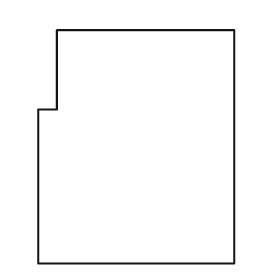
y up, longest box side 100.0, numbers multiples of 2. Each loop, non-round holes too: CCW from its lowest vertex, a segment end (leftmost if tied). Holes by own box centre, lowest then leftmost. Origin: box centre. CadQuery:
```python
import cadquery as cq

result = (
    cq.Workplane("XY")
    .moveTo(-42.0, -50.0)
    .lineTo(42.0, -50.0)
    .lineTo(42.0, 50.0)
    .lineTo(-34.0, 50.0)
    .lineTo(-34.0, 16.0)
    .lineTo(-42.0, 16.0)
    .close()
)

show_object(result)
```